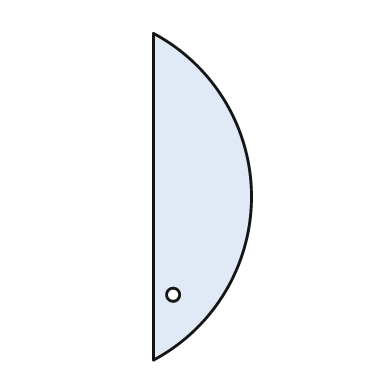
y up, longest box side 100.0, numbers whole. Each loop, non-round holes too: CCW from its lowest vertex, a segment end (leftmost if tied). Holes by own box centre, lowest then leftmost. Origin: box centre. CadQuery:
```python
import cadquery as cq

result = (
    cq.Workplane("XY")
    .moveTo(-15.0, -50.0)
    .threePointArc((15.0, 0.0), (-15.0, 50.0))
    .close()
    .moveTo(-9.0, -30.0)
    .circle(2.0)
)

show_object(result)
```